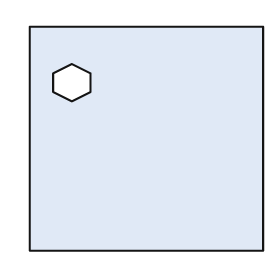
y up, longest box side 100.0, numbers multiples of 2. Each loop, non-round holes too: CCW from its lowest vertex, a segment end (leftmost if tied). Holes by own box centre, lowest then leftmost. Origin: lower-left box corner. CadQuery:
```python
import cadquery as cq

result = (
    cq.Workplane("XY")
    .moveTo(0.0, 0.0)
    .lineTo(100.0, 0.0)
    .lineTo(100.0, 96.0)
    .lineTo(0.0, 96.0)
    .close()
    .moveTo(18.0, 64.0)
    .lineTo(26.0, 68.0)
    .lineTo(26.0, 76.0)
    .lineTo(18.0, 80.0)
    .lineTo(10.0, 76.0)
    .lineTo(10.0, 68.0)
    .close()
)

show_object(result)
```